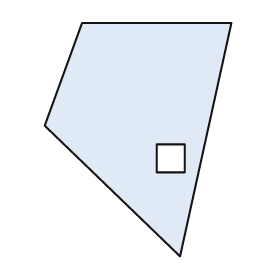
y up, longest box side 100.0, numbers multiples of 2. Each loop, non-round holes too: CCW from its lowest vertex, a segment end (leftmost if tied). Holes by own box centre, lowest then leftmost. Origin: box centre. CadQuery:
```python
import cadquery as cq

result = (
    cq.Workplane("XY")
    .moveTo(18.0, -50.0)
    .lineTo(40.0, 50.0)
    .lineTo(-24.0, 50.0)
    .lineTo(-40.0, 6.0)
    .close()
    .moveTo(8.0, -14.0)
    .lineTo(20.0, -14.0)
    .lineTo(20.0, -2.0)
    .lineTo(8.0, -2.0)
    .close()
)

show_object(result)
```